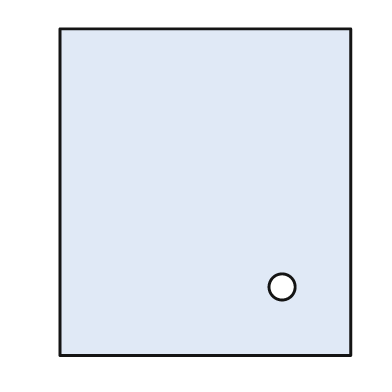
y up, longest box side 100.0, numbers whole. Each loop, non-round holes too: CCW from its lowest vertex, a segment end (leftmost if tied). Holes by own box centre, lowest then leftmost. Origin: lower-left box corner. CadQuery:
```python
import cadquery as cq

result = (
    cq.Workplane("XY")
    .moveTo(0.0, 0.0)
    .lineTo(89.0, 0.0)
    .lineTo(89.0, 100.0)
    .lineTo(0.0, 100.0)
    .close()
    .moveTo(68.0, 21.0)
    .circle(4.0)
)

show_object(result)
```